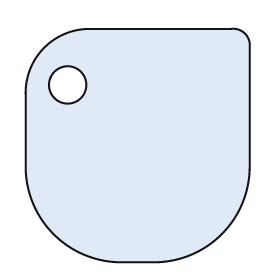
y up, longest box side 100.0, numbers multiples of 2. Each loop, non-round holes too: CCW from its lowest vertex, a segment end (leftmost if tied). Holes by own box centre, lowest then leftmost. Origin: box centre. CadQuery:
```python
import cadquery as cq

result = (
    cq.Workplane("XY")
    .moveTo(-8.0, -50.0)
    .lineTo(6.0, -50.0)
    .threePointArc((36.0, -38.0), (48.0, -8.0))
    .lineTo(48.0, 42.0)
    .threePointArc((46.0, 48.0), (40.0, 50.0))
    .lineTo(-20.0, 50.0)
    .threePointArc((-40.0, 42.0), (-48.0, 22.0))
    .lineTo(-48.0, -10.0)
    .threePointArc((-36.0, -38.0), (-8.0, -50.0))
    .close()
    .moveTo(-30.0, 26.0)
    .circle(8.0)
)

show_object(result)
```